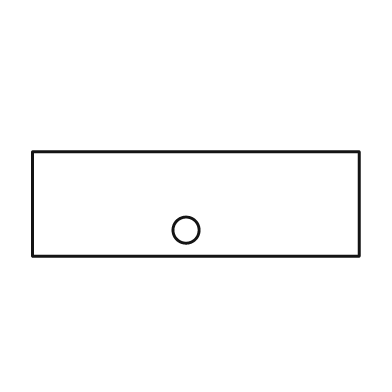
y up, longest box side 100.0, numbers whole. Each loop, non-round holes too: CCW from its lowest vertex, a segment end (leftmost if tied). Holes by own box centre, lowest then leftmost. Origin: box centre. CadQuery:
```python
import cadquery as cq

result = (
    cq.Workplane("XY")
    .moveTo(-50.0, -16.0)
    .lineTo(50.0, -16.0)
    .lineTo(50.0, 16.0)
    .lineTo(-50.0, 16.0)
    .close()
    .moveTo(-3.0, -8.0)
    .circle(4.0)
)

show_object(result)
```